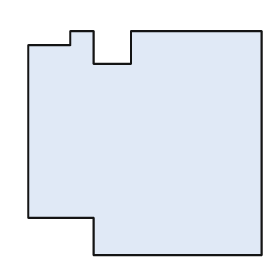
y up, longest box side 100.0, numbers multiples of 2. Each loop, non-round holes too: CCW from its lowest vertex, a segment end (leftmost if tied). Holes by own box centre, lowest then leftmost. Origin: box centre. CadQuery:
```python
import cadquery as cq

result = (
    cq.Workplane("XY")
    .moveTo(-22.0, -48.0)
    .lineTo(50.0, -48.0)
    .lineTo(50.0, 48.0)
    .lineTo(-6.0, 48.0)
    .lineTo(-6.0, 34.0)
    .lineTo(-22.0, 34.0)
    .lineTo(-22.0, 48.0)
    .lineTo(-32.0, 48.0)
    .lineTo(-32.0, 42.0)
    .lineTo(-50.0, 42.0)
    .lineTo(-50.0, -32.0)
    .lineTo(-22.0, -32.0)
    .close()
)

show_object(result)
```